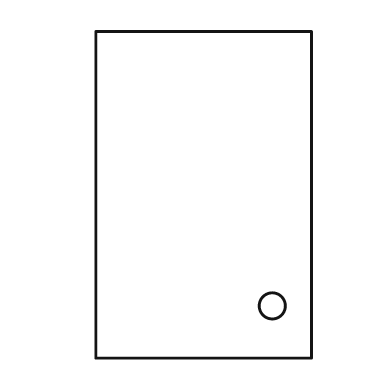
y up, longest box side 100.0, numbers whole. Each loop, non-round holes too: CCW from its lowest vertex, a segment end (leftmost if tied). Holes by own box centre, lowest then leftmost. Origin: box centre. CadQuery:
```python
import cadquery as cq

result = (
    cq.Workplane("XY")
    .moveTo(-33.0, -50.0)
    .lineTo(33.0, -50.0)
    .lineTo(33.0, 50.0)
    .lineTo(-33.0, 50.0)
    .close()
    .moveTo(21.0, -34.0)
    .circle(4.0)
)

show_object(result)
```